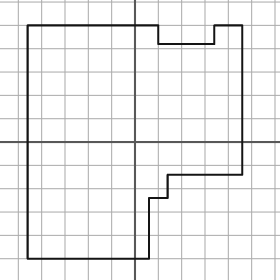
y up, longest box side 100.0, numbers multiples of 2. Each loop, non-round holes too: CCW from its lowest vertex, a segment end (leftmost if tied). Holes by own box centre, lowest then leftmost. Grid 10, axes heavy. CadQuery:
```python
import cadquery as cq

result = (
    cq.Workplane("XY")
    .moveTo(-46.0, -50.0)
    .lineTo(6.0, -50.0)
    .lineTo(6.0, -24.0)
    .lineTo(14.0, -24.0)
    .lineTo(14.0, -14.0)
    .lineTo(46.0, -14.0)
    .lineTo(46.0, 50.0)
    .lineTo(34.0, 50.0)
    .lineTo(34.0, 42.0)
    .lineTo(10.0, 42.0)
    .lineTo(10.0, 50.0)
    .lineTo(-46.0, 50.0)
    .close()
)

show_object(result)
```